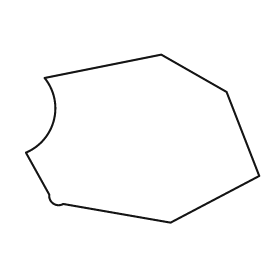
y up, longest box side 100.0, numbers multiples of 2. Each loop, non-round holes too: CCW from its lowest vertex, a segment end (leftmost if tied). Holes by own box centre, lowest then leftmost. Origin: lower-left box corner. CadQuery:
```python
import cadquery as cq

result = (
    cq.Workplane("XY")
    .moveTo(62.0, 0.0)
    .lineTo(100.0, 20.0)
    .lineTo(86.0, 56.0)
    .lineTo(58.0, 72.0)
    .lineTo(8.0, 62.0)
    .threePointArc((12.0, 44.0), (0.0, 30.0))
    .lineTo(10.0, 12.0)
    .threePointArc((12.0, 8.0), (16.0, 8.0))
    .close()
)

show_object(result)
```